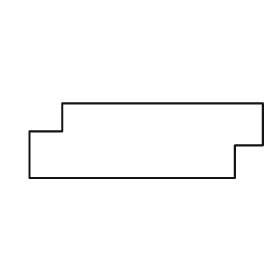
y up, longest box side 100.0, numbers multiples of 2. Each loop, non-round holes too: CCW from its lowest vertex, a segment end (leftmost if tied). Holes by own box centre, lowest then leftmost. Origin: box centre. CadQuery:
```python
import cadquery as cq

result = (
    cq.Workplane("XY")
    .moveTo(-50.0, -16.0)
    .lineTo(38.0, -16.0)
    .lineTo(38.0, -2.0)
    .lineTo(50.0, -2.0)
    .lineTo(50.0, 16.0)
    .lineTo(-36.0, 16.0)
    .lineTo(-36.0, 4.0)
    .lineTo(-50.0, 4.0)
    .close()
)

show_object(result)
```